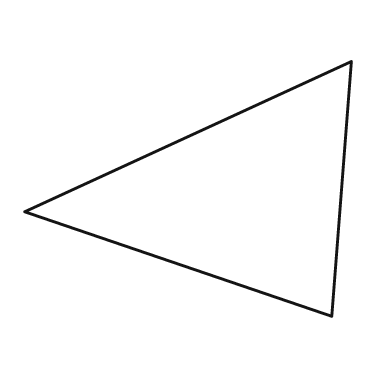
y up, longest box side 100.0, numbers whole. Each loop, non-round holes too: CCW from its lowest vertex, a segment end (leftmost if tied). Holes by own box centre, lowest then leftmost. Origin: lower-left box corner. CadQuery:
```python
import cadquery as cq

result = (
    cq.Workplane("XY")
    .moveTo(94.0, 0.0)
    .lineTo(100.0, 78.0)
    .lineTo(0.0, 32.0)
    .close()
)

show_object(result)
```